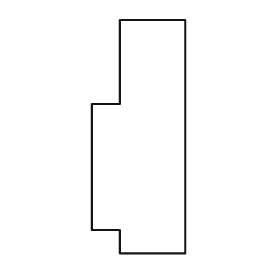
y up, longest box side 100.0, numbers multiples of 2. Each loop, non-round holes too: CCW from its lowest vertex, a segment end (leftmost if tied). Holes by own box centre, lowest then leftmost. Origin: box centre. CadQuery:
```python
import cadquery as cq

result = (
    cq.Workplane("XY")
    .moveTo(-8.0, -50.0)
    .lineTo(20.0, -50.0)
    .lineTo(20.0, 50.0)
    .lineTo(-8.0, 50.0)
    .lineTo(-8.0, 14.0)
    .lineTo(-20.0, 14.0)
    .lineTo(-20.0, -40.0)
    .lineTo(-8.0, -40.0)
    .close()
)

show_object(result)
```